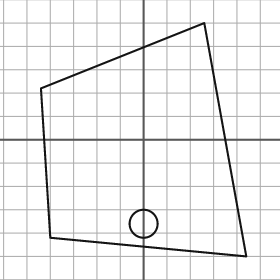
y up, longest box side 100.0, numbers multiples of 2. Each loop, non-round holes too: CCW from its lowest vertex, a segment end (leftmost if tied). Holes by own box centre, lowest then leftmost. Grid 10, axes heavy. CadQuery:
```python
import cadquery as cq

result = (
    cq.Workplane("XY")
    .moveTo(44.0, -50.0)
    .lineTo(26.0, 50.0)
    .lineTo(-44.0, 22.0)
    .lineTo(-40.0, -42.0)
    .close()
    .moveTo(0.0, -36.0)
    .circle(6.0)
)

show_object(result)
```